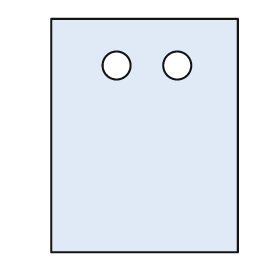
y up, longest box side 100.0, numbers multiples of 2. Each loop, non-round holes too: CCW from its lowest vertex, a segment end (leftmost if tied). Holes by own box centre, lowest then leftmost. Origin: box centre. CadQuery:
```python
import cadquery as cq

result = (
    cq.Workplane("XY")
    .moveTo(-40.0, -50.0)
    .lineTo(40.0, -50.0)
    .lineTo(40.0, 50.0)
    .lineTo(-40.0, 50.0)
    .close()
    .moveTo(-12.0, 30.0)
    .circle(6.0)
    .moveTo(14.0, 30.0)
    .circle(6.0)
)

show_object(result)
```